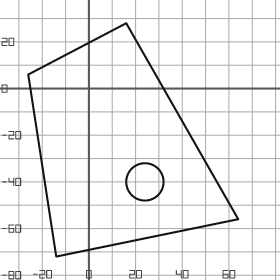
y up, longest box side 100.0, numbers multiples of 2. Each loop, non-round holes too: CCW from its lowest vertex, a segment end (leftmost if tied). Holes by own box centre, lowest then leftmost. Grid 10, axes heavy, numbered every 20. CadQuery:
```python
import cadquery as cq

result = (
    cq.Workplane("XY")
    .moveTo(-14.0, -72.0)
    .lineTo(64.0, -56.0)
    .lineTo(16.0, 28.0)
    .lineTo(-26.0, 6.0)
    .close()
    .moveTo(24.0, -40.0)
    .circle(8.0)
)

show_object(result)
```